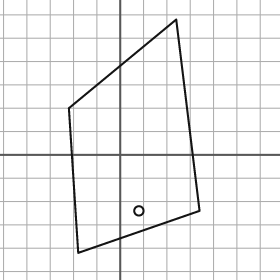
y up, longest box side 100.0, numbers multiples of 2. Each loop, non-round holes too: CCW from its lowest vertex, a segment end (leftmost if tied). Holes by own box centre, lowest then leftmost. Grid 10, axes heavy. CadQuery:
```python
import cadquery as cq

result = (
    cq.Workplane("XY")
    .moveTo(-18.0, -42.0)
    .lineTo(34.0, -24.0)
    .lineTo(24.0, 58.0)
    .lineTo(-22.0, 20.0)
    .close()
    .moveTo(8.0, -24.0)
    .circle(2.0)
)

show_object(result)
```